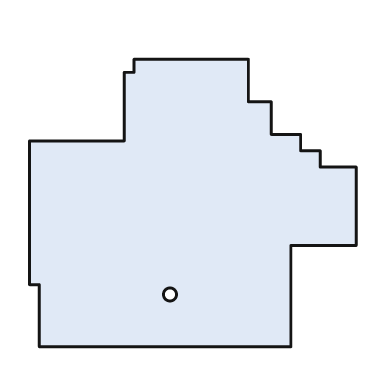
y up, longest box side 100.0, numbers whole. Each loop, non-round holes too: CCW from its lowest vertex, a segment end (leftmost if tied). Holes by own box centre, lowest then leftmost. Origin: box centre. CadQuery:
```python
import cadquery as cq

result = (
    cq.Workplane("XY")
    .moveTo(-47.0, -44.0)
    .lineTo(30.0, -44.0)
    .lineTo(30.0, -13.0)
    .lineTo(50.0, -13.0)
    .lineTo(50.0, 11.0)
    .lineTo(39.0, 11.0)
    .lineTo(39.0, 16.0)
    .lineTo(33.0, 16.0)
    .lineTo(33.0, 21.0)
    .lineTo(24.0, 21.0)
    .lineTo(24.0, 31.0)
    .lineTo(17.0, 31.0)
    .lineTo(17.0, 44.0)
    .lineTo(-18.0, 44.0)
    .lineTo(-18.0, 40.0)
    .lineTo(-21.0, 40.0)
    .lineTo(-21.0, 19.0)
    .lineTo(-50.0, 19.0)
    .lineTo(-50.0, -25.0)
    .lineTo(-47.0, -25.0)
    .close()
    .moveTo(-7.0, -28.0)
    .circle(2.0)
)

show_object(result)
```